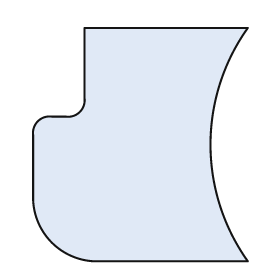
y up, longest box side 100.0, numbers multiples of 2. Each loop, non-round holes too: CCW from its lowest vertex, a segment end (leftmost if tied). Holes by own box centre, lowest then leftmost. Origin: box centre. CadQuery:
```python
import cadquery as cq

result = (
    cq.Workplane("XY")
    .moveTo(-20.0, -50.0)
    .lineTo(46.0, -50.0)
    .threePointArc((30.0, 0.0), (46.0, 50.0))
    .lineTo(-24.0, 50.0)
    .lineTo(-24.0, 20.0)
    .threePointArc((-26.0, 14.0), (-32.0, 12.0))
    .lineTo(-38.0, 12.0)
    .threePointArc((-44.0, 10.0), (-46.0, 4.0))
    .lineTo(-46.0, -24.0)
    .threePointArc((-38.0, -42.0), (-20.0, -50.0))
    .close()
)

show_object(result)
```